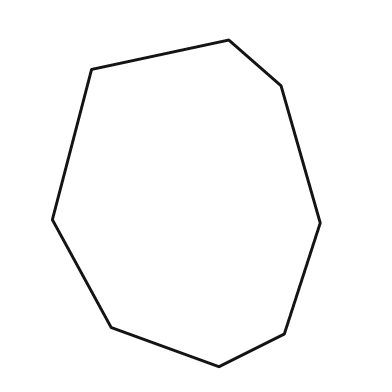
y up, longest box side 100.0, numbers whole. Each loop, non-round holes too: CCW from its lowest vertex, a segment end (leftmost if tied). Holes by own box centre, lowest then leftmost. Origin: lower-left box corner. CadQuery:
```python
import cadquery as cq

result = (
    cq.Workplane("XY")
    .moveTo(51.0, 0.0)
    .lineTo(71.0, 10.0)
    .lineTo(82.0, 44.0)
    .lineTo(70.0, 86.0)
    .lineTo(54.0, 100.0)
    .lineTo(12.0, 91.0)
    .lineTo(0.0, 45.0)
    .lineTo(18.0, 12.0)
    .close()
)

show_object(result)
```